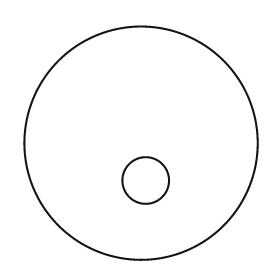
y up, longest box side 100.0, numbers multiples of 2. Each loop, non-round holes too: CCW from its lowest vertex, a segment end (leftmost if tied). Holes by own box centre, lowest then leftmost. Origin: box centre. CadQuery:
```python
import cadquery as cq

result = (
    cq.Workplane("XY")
    .moveTo(0.0, 0.0)
    .circle(50.0)
    .moveTo(2.0, -16.0)
    .circle(10.0)
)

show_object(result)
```